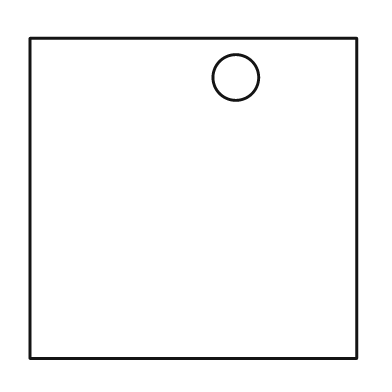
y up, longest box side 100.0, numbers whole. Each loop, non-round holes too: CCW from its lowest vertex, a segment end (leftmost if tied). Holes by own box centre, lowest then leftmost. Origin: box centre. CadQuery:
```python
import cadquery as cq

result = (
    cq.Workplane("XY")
    .moveTo(-50.0, -49.0)
    .lineTo(50.0, -49.0)
    .lineTo(50.0, 49.0)
    .lineTo(-50.0, 49.0)
    .close()
    .moveTo(13.0, 37.0)
    .circle(7.0)
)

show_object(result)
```